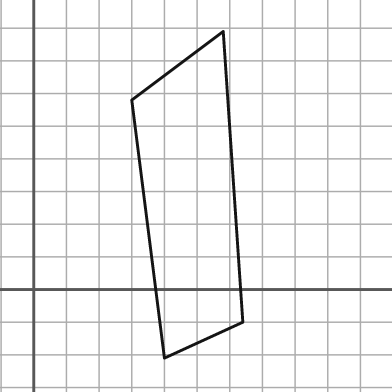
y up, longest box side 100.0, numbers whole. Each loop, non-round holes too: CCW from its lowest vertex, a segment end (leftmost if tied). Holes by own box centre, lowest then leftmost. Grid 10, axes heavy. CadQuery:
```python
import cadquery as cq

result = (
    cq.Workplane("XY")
    .moveTo(40.0, -21.0)
    .lineTo(64.0, -10.0)
    .lineTo(58.0, 79.0)
    .lineTo(30.0, 58.0)
    .close()
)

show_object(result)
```